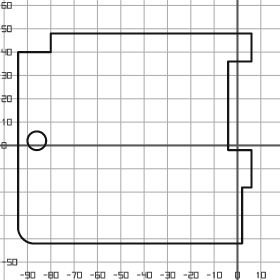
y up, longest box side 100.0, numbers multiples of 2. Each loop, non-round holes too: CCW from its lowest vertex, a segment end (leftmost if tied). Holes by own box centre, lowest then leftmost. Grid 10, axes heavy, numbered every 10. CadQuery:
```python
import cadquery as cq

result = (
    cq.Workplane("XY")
    .moveTo(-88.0, -42.0)
    .lineTo(2.0, -42.0)
    .lineTo(2.0, -18.0)
    .lineTo(6.0, -18.0)
    .lineTo(6.0, -2.0)
    .lineTo(-4.0, -2.0)
    .lineTo(-4.0, 36.0)
    .lineTo(6.0, 36.0)
    .lineTo(6.0, 48.0)
    .lineTo(-80.0, 48.0)
    .lineTo(-80.0, 40.0)
    .lineTo(-94.0, 40.0)
    .lineTo(-94.0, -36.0)
    .threePointArc((-92.0, -40.0), (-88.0, -42.0))
    .close()
    .moveTo(-86.0, 2.0)
    .circle(4.0)
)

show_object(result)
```